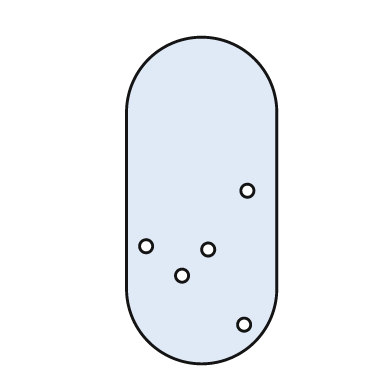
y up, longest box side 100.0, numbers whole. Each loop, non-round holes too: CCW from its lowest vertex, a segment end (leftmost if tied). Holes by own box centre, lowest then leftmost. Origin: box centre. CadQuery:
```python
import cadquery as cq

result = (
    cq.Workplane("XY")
    .moveTo(-23.0, -27.0)
    .threePointArc((0.0, -50.0), (23.0, -27.0))
    .lineTo(23.0, 27.0)
    .threePointArc((0.0, 50.0), (-23.0, 27.0))
    .close()
    .moveTo(13.0, -38.0)
    .circle(2.0)
    .moveTo(-6.0, -23.0)
    .circle(2.0)
    .moveTo(2.0, -15.0)
    .circle(2.0)
    .moveTo(-17.0, -14.0)
    .circle(2.0)
    .moveTo(14.0, 3.0)
    .circle(2.0)
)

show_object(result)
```